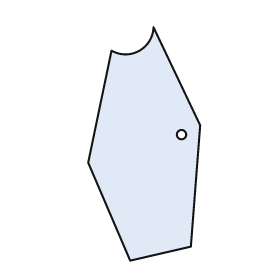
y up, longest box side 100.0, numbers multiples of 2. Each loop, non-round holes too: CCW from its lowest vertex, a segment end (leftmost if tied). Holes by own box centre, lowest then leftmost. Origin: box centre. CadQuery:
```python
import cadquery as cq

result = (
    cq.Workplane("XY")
    .moveTo(-6.0, -50.0)
    .lineTo(20.0, -44.0)
    .lineTo(24.0, 8.0)
    .lineTo(4.0, 50.0)
    .threePointArc((-2.0, 40.0), (-14.0, 40.0))
    .lineTo(-24.0, -8.0)
    .close()
    .moveTo(16.0, 4.0)
    .circle(2.0)
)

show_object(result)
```